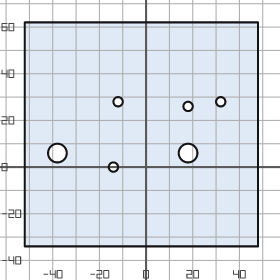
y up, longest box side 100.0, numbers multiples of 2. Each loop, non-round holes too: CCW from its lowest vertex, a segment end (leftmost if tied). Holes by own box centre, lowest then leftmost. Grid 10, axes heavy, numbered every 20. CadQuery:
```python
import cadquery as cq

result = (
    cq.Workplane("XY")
    .moveTo(-52.0, -34.0)
    .lineTo(48.0, -34.0)
    .lineTo(48.0, 62.0)
    .lineTo(-52.0, 62.0)
    .close()
    .moveTo(-14.0, 0.0)
    .circle(2.0)
    .moveTo(-38.0, 6.0)
    .circle(4.0)
    .moveTo(18.0, 6.0)
    .circle(4.0)
    .moveTo(18.0, 26.0)
    .circle(2.0)
    .moveTo(-12.0, 28.0)
    .circle(2.0)
    .moveTo(32.0, 28.0)
    .circle(2.0)
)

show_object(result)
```